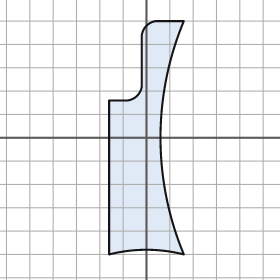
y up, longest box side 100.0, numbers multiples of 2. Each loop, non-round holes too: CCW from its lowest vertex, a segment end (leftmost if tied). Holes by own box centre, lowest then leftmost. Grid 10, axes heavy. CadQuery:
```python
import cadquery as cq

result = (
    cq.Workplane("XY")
    .moveTo(-16.0, -50.0)
    .threePointArc((0.0, -48.0), (16.0, -50.0))
    .threePointArc((6.0, 0.0), (16.0, 50.0))
    .lineTo(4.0, 50.0)
    .threePointArc((0.0, 48.0), (-2.0, 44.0))
    .lineTo(-2.0, 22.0)
    .threePointArc((-4.0, 18.0), (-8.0, 16.0))
    .lineTo(-16.0, 16.0)
    .close()
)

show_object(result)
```